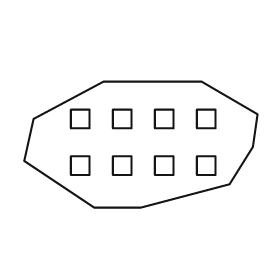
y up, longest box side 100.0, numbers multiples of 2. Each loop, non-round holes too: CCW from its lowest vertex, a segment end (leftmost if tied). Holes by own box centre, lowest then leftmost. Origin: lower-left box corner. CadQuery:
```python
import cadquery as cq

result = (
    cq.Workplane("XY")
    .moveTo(30.0, 0.0)
    .lineTo(50.0, 0.0)
    .lineTo(88.0, 10.0)
    .lineTo(98.0, 26.0)
    .lineTo(100.0, 40.0)
    .lineTo(76.0, 54.0)
    .lineTo(34.0, 54.0)
    .lineTo(4.0, 38.0)
    .lineTo(0.0, 20.0)
    .close()
    .moveTo(20.0, 14.0)
    .lineTo(28.0, 14.0)
    .lineTo(28.0, 22.0)
    .lineTo(20.0, 22.0)
    .close()
    .moveTo(38.0, 14.0)
    .lineTo(46.0, 14.0)
    .lineTo(46.0, 22.0)
    .lineTo(38.0, 22.0)
    .close()
    .moveTo(56.0, 14.0)
    .lineTo(64.0, 14.0)
    .lineTo(64.0, 22.0)
    .lineTo(56.0, 22.0)
    .close()
    .moveTo(74.0, 14.0)
    .lineTo(82.0, 14.0)
    .lineTo(82.0, 22.0)
    .lineTo(74.0, 22.0)
    .close()
    .moveTo(20.0, 34.0)
    .lineTo(28.0, 34.0)
    .lineTo(28.0, 42.0)
    .lineTo(20.0, 42.0)
    .close()
    .moveTo(38.0, 34.0)
    .lineTo(46.0, 34.0)
    .lineTo(46.0, 42.0)
    .lineTo(38.0, 42.0)
    .close()
    .moveTo(56.0, 34.0)
    .lineTo(64.0, 34.0)
    .lineTo(64.0, 42.0)
    .lineTo(56.0, 42.0)
    .close()
    .moveTo(74.0, 34.0)
    .lineTo(82.0, 34.0)
    .lineTo(82.0, 42.0)
    .lineTo(74.0, 42.0)
    .close()
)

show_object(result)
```